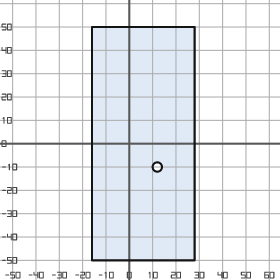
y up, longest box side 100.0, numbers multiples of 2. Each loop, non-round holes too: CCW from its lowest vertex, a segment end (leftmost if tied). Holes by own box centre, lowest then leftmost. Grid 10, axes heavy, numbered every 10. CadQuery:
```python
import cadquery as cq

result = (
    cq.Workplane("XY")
    .moveTo(-16.0, -50.0)
    .lineTo(28.0, -50.0)
    .lineTo(28.0, 50.0)
    .lineTo(-16.0, 50.0)
    .close()
    .moveTo(12.0, -10.0)
    .circle(2.0)
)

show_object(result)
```